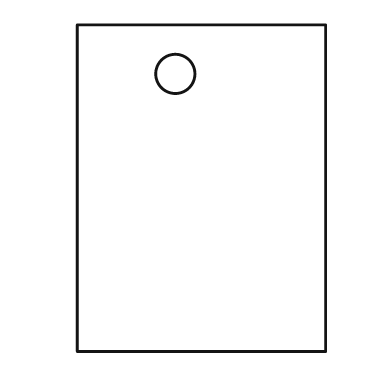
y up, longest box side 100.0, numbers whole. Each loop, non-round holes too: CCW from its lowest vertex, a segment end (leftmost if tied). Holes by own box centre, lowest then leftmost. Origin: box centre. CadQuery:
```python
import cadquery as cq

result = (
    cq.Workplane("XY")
    .moveTo(-38.0, -50.0)
    .lineTo(38.0, -50.0)
    .lineTo(38.0, 50.0)
    .lineTo(-38.0, 50.0)
    .close()
    .moveTo(-8.0, 35.0)
    .circle(6.0)
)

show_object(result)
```